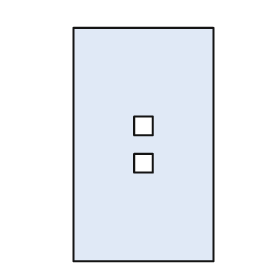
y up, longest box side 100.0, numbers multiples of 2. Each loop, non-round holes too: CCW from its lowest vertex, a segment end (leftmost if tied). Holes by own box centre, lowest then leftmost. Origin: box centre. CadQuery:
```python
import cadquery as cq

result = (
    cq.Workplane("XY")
    .moveTo(-30.0, -50.0)
    .lineTo(30.0, -50.0)
    .lineTo(30.0, 50.0)
    .lineTo(-30.0, 50.0)
    .close()
    .moveTo(-4.0, -12.0)
    .lineTo(4.0, -12.0)
    .lineTo(4.0, -4.0)
    .lineTo(-4.0, -4.0)
    .close()
    .moveTo(-4.0, 4.0)
    .lineTo(4.0, 4.0)
    .lineTo(4.0, 12.0)
    .lineTo(-4.0, 12.0)
    .close()
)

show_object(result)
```